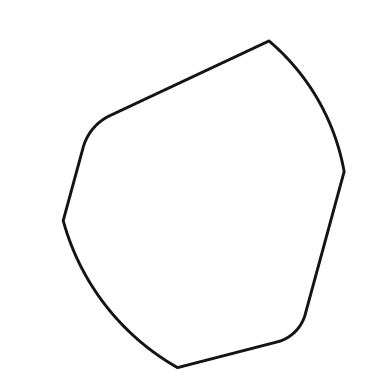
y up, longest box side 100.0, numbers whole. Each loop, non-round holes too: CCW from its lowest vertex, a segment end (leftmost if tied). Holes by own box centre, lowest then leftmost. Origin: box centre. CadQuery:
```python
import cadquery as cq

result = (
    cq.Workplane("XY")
    .moveTo(-8.0, -50.0)
    .lineTo(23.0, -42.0)
    .threePointArc((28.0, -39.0), (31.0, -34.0))
    .lineTo(43.0, 10.0)
    .threePointArc((35.0, 32.0), (20.0, 50.0))
    .lineTo(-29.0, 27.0)
    .threePointArc((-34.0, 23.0), (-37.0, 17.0))
    .lineTo(-43.0, -5.0)
    .threePointArc((-30.0, -31.0), (-8.0, -50.0))
    .close()
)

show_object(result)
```